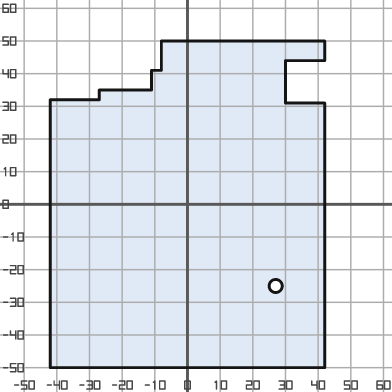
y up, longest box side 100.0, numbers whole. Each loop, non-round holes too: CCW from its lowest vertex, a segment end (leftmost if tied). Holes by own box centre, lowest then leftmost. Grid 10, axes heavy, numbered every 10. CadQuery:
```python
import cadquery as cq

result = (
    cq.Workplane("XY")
    .moveTo(-42.0, -50.0)
    .lineTo(42.0, -50.0)
    .lineTo(42.0, 31.0)
    .lineTo(30.0, 31.0)
    .lineTo(30.0, 44.0)
    .lineTo(42.0, 44.0)
    .lineTo(42.0, 50.0)
    .lineTo(-8.0, 50.0)
    .lineTo(-8.0, 41.0)
    .lineTo(-11.0, 41.0)
    .lineTo(-11.0, 35.0)
    .lineTo(-27.0, 35.0)
    .lineTo(-27.0, 32.0)
    .lineTo(-42.0, 32.0)
    .close()
    .moveTo(27.0, -25.0)
    .circle(2.0)
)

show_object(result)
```